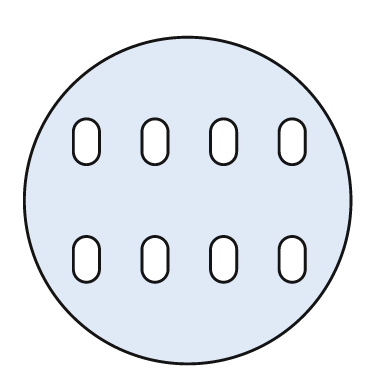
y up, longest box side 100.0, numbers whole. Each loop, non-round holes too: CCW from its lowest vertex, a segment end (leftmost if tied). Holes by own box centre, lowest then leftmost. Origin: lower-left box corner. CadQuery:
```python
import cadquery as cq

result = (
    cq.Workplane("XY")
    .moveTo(50.0, 50.0)
    .circle(50.0)
    .moveTo(15.0, 29.0)
    .threePointArc((19.0, 25.0), (23.0, 29.0))
    .lineTo(23.0, 35.0)
    .threePointArc((19.0, 39.0), (15.0, 35.0))
    .close()
    .moveTo(36.0, 29.0)
    .threePointArc((40.0, 25.0), (44.0, 29.0))
    .lineTo(44.0, 35.0)
    .threePointArc((40.0, 39.0), (36.0, 35.0))
    .close()
    .moveTo(57.0, 29.0)
    .threePointArc((61.0, 25.0), (65.0, 29.0))
    .lineTo(65.0, 35.0)
    .threePointArc((61.0, 39.0), (57.0, 35.0))
    .close()
    .moveTo(78.0, 29.0)
    .threePointArc((82.0, 25.0), (86.0, 29.0))
    .lineTo(86.0, 35.0)
    .threePointArc((82.0, 39.0), (78.0, 35.0))
    .close()
    .moveTo(15.0, 65.0)
    .threePointArc((19.0, 61.0), (23.0, 65.0))
    .lineTo(23.0, 71.0)
    .threePointArc((19.0, 75.0), (15.0, 71.0))
    .close()
    .moveTo(36.0, 65.0)
    .threePointArc((40.0, 61.0), (44.0, 65.0))
    .lineTo(44.0, 71.0)
    .threePointArc((40.0, 75.0), (36.0, 71.0))
    .close()
    .moveTo(57.0, 65.0)
    .threePointArc((61.0, 61.0), (65.0, 65.0))
    .lineTo(65.0, 71.0)
    .threePointArc((61.0, 75.0), (57.0, 71.0))
    .close()
    .moveTo(78.0, 65.0)
    .threePointArc((82.0, 61.0), (86.0, 65.0))
    .lineTo(86.0, 71.0)
    .threePointArc((82.0, 75.0), (78.0, 71.0))
    .close()
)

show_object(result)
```